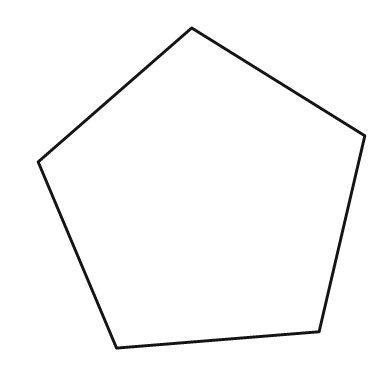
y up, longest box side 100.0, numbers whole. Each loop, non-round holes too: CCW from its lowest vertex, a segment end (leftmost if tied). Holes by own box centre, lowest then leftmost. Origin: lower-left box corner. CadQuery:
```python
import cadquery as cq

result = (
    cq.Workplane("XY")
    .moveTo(24.0, 0.0)
    .lineTo(86.0, 5.0)
    .lineTo(100.0, 65.0)
    .lineTo(47.0, 98.0)
    .lineTo(0.0, 57.0)
    .close()
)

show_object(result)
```